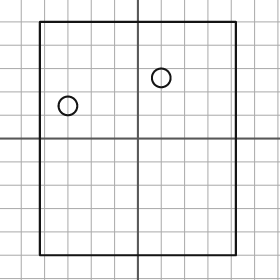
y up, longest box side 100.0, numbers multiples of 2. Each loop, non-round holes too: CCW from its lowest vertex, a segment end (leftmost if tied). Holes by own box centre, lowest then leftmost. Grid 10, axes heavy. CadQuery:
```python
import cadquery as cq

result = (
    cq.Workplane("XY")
    .moveTo(-42.0, -50.0)
    .lineTo(42.0, -50.0)
    .lineTo(42.0, 50.0)
    .lineTo(-42.0, 50.0)
    .close()
    .moveTo(-30.0, 14.0)
    .circle(4.0)
    .moveTo(10.0, 26.0)
    .circle(4.0)
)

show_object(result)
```